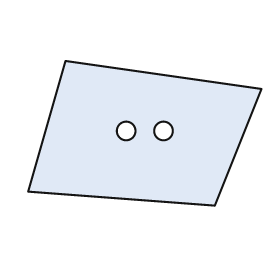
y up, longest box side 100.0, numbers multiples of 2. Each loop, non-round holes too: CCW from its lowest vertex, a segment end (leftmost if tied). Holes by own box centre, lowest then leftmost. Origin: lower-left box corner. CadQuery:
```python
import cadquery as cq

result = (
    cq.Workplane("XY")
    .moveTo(80.0, 0.0)
    .lineTo(100.0, 50.0)
    .lineTo(16.0, 62.0)
    .lineTo(0.0, 6.0)
    .close()
    .moveTo(42.0, 32.0)
    .circle(4.0)
    .moveTo(58.0, 32.0)
    .circle(4.0)
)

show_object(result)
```